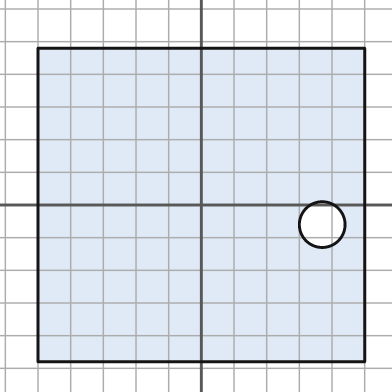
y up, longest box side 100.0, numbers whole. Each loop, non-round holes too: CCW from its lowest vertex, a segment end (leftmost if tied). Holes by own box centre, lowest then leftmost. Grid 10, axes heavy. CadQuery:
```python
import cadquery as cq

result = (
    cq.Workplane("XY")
    .moveTo(-50.0, -48.0)
    .lineTo(50.0, -48.0)
    .lineTo(50.0, 48.0)
    .lineTo(-50.0, 48.0)
    .close()
    .moveTo(37.0, -6.0)
    .circle(7.0)
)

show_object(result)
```